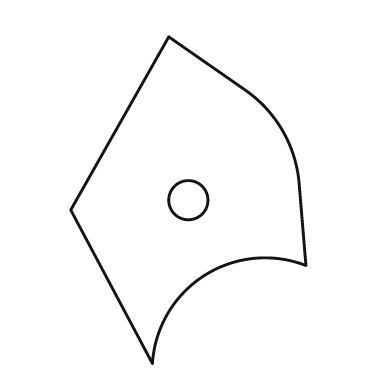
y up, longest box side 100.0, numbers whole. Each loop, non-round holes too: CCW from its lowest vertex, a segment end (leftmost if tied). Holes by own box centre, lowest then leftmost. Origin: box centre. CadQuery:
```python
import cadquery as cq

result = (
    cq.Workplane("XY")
    .moveTo(-11.0, -50.0)
    .threePointArc((5.0, -23.0), (36.0, -20.0))
    .lineTo(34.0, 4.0)
    .threePointArc((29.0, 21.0), (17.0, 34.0))
    .lineTo(-6.0, 50.0)
    .lineTo(-36.0, -3.0)
    .close()
    .moveTo(0.0, 0.0)
    .circle(6.0)
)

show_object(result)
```